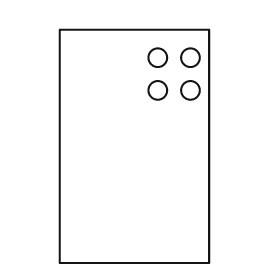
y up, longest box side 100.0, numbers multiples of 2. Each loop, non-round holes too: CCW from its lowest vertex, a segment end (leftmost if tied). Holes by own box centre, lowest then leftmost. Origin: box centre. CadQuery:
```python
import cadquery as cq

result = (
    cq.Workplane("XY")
    .moveTo(-32.0, -50.0)
    .lineTo(32.0, -50.0)
    .lineTo(32.0, 50.0)
    .lineTo(-32.0, 50.0)
    .close()
    .moveTo(10.0, 24.0)
    .circle(4.0)
    .moveTo(24.0, 24.0)
    .circle(4.0)
    .moveTo(10.0, 38.0)
    .circle(4.0)
    .moveTo(24.0, 38.0)
    .circle(4.0)
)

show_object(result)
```